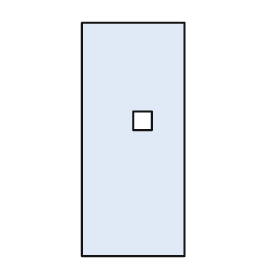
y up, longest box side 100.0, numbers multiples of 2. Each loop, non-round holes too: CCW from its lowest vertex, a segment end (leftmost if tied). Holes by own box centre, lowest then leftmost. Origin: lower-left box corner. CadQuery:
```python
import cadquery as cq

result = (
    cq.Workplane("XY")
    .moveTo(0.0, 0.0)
    .lineTo(44.0, 0.0)
    .lineTo(44.0, 100.0)
    .lineTo(0.0, 100.0)
    .close()
    .moveTo(22.0, 54.0)
    .lineTo(30.0, 54.0)
    .lineTo(30.0, 62.0)
    .lineTo(22.0, 62.0)
    .close()
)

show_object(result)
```